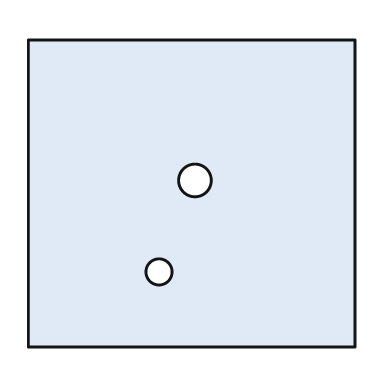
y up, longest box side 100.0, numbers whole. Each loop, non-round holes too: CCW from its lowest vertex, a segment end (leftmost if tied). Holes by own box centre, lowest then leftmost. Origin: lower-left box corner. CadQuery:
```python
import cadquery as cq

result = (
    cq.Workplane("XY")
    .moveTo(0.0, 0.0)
    .lineTo(100.0, 0.0)
    .lineTo(100.0, 94.0)
    .lineTo(0.0, 94.0)
    .close()
    .moveTo(40.0, 23.0)
    .circle(4.0)
    .moveTo(51.0, 51.0)
    .circle(5.0)
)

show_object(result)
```